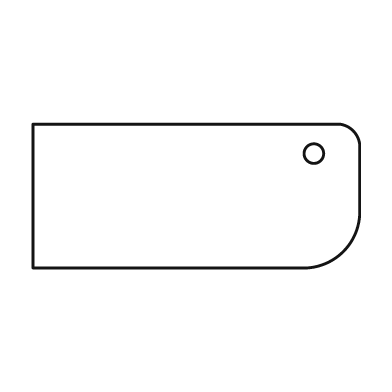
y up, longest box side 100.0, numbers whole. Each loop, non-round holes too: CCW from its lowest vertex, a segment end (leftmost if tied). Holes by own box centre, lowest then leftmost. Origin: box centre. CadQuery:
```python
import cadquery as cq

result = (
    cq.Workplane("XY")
    .moveTo(-50.0, -22.0)
    .lineTo(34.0, -22.0)
    .threePointArc((45.0, -17.0), (50.0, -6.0))
    .lineTo(50.0, 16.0)
    .threePointArc((48.0, 20.0), (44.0, 22.0))
    .lineTo(-50.0, 22.0)
    .close()
    .moveTo(36.0, 13.0)
    .circle(3.0)
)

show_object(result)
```